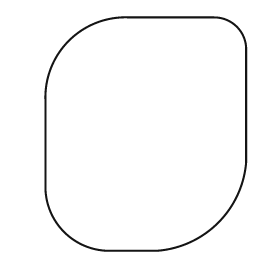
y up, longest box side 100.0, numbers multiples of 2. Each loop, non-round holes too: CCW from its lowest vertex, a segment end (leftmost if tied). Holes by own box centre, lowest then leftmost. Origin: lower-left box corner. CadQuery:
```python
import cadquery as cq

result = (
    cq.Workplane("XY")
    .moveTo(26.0, 0.0)
    .lineTo(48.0, 0.0)
    .threePointArc((74.0, 12.0), (86.0, 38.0))
    .lineTo(86.0, 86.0)
    .threePointArc((82.0, 96.0), (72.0, 100.0))
    .lineTo(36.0, 100.0)
    .threePointArc((10.0, 90.0), (0.0, 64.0))
    .lineTo(0.0, 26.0)
    .threePointArc((8.0, 8.0), (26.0, 0.0))
    .close()
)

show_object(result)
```